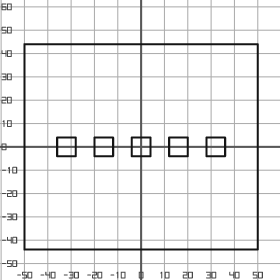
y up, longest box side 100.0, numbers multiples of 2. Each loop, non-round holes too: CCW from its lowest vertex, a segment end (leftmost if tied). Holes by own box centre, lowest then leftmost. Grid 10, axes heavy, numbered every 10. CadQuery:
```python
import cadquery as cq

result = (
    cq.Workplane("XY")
    .moveTo(-50.0, -44.0)
    .lineTo(50.0, -44.0)
    .lineTo(50.0, 44.0)
    .lineTo(-50.0, 44.0)
    .close()
    .moveTo(-36.0, -4.0)
    .lineTo(-28.0, -4.0)
    .lineTo(-28.0, 4.0)
    .lineTo(-36.0, 4.0)
    .close()
    .moveTo(-20.0, -4.0)
    .lineTo(-12.0, -4.0)
    .lineTo(-12.0, 4.0)
    .lineTo(-20.0, 4.0)
    .close()
    .moveTo(-4.0, -4.0)
    .lineTo(4.0, -4.0)
    .lineTo(4.0, 4.0)
    .lineTo(-4.0, 4.0)
    .close()
    .moveTo(12.0, -4.0)
    .lineTo(20.0, -4.0)
    .lineTo(20.0, 4.0)
    .lineTo(12.0, 4.0)
    .close()
    .moveTo(28.0, -4.0)
    .lineTo(36.0, -4.0)
    .lineTo(36.0, 4.0)
    .lineTo(28.0, 4.0)
    .close()
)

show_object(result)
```